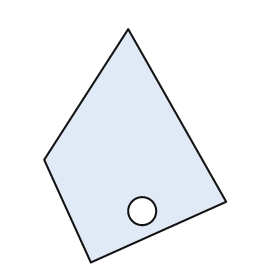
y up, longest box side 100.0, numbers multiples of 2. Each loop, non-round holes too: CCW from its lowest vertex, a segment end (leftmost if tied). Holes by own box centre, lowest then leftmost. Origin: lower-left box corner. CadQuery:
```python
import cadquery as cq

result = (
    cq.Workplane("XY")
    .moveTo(20.0, 0.0)
    .lineTo(78.0, 26.0)
    .lineTo(36.0, 100.0)
    .lineTo(0.0, 44.0)
    .close()
    .moveTo(42.0, 22.0)
    .circle(6.0)
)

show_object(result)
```